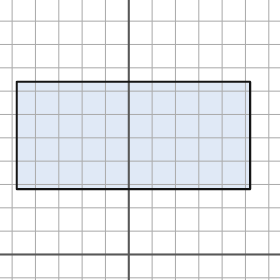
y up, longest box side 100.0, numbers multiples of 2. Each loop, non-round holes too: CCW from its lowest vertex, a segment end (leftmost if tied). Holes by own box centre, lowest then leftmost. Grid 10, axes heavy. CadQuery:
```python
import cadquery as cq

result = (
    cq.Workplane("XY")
    .moveTo(-48.0, 28.0)
    .lineTo(52.0, 28.0)
    .lineTo(52.0, 74.0)
    .lineTo(-48.0, 74.0)
    .close()
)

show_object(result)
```